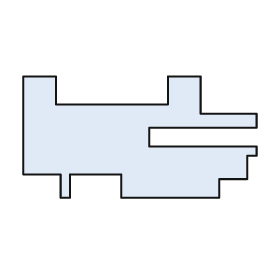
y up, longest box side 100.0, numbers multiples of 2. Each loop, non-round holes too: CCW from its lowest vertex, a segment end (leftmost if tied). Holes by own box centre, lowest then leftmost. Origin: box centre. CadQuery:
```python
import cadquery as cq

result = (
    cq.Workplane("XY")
    .moveTo(-34.0, -26.0)
    .lineTo(-30.0, -26.0)
    .lineTo(-30.0, -16.0)
    .lineTo(-8.0, -16.0)
    .lineTo(-8.0, -26.0)
    .lineTo(34.0, -26.0)
    .lineTo(34.0, -18.0)
    .lineTo(46.0, -18.0)
    .lineTo(46.0, -8.0)
    .lineTo(50.0, -8.0)
    .lineTo(50.0, -4.0)
    .lineTo(4.0, -4.0)
    .lineTo(4.0, 4.0)
    .lineTo(50.0, 4.0)
    .lineTo(50.0, 10.0)
    .lineTo(26.0, 10.0)
    .lineTo(26.0, 26.0)
    .lineTo(12.0, 26.0)
    .lineTo(12.0, 14.0)
    .lineTo(-36.0, 14.0)
    .lineTo(-36.0, 26.0)
    .lineTo(-50.0, 26.0)
    .lineTo(-50.0, -16.0)
    .lineTo(-34.0, -16.0)
    .close()
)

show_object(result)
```